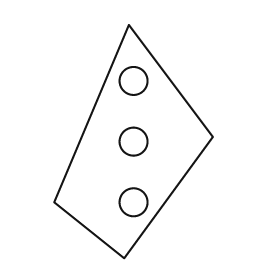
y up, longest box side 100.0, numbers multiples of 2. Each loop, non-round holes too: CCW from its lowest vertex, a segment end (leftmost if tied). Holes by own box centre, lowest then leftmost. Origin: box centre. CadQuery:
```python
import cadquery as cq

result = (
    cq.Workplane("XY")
    .moveTo(-4.0, -50.0)
    .lineTo(34.0, 2.0)
    .lineTo(-2.0, 50.0)
    .lineTo(-34.0, -26.0)
    .close()
    .moveTo(0.0, -26.0)
    .circle(6.0)
    .moveTo(0.0, 0.0)
    .circle(6.0)
    .moveTo(0.0, 26.0)
    .circle(6.0)
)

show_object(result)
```